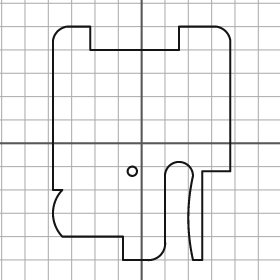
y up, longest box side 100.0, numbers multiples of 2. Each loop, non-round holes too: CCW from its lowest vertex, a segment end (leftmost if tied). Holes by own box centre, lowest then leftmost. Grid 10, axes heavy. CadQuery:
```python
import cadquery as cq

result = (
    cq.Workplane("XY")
    .moveTo(-8.0, -50.0)
    .lineTo(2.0, -50.0)
    .threePointArc((8.0, -48.0), (10.0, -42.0))
    .lineTo(10.0, -14.0)
    .threePointArc((16.0, -8.0), (22.0, -14.0))
    .threePointArc((20.0, -32.0), (22.0, -50.0))
    .lineTo(26.0, -50.0)
    .lineTo(26.0, -12.0)
    .lineTo(38.0, -12.0)
    .lineTo(38.0, 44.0)
    .threePointArc((36.0, 48.0), (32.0, 50.0))
    .lineTo(16.0, 50.0)
    .lineTo(16.0, 40.0)
    .lineTo(-22.0, 40.0)
    .lineTo(-22.0, 50.0)
    .lineTo(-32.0, 50.0)
    .threePointArc((-36.0, 48.0), (-38.0, 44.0))
    .lineTo(-38.0, -20.0)
    .lineTo(-34.0, -20.0)
    .threePointArc((-38.0, -30.0), (-34.0, -40.0))
    .lineTo(-8.0, -40.0)
    .close()
    .moveTo(-4.0, -12.0)
    .circle(2.0)
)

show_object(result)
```